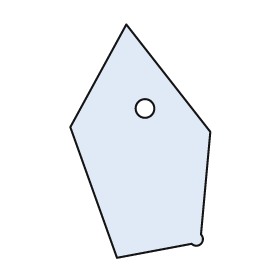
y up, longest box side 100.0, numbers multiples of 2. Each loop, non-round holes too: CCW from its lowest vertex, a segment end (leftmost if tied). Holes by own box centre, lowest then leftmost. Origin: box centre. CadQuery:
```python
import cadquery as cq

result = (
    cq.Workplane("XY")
    .moveTo(-10.0, -50.0)
    .lineTo(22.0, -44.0)
    .threePointArc((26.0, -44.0), (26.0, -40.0))
    .lineTo(30.0, 4.0)
    .lineTo(-6.0, 50.0)
    .lineTo(-30.0, 6.0)
    .close()
    .moveTo(2.0, 14.0)
    .circle(4.0)
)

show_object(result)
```